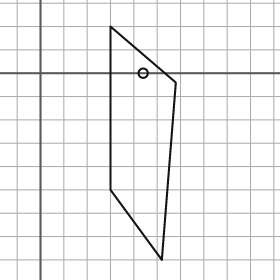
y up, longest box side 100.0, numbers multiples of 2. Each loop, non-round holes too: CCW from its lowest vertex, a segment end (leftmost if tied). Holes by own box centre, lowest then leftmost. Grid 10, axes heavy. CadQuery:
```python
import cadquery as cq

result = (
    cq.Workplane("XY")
    .moveTo(52.0, -80.0)
    .lineTo(58.0, -4.0)
    .lineTo(30.0, 20.0)
    .lineTo(30.0, -50.0)
    .close()
    .moveTo(44.0, 0.0)
    .circle(2.0)
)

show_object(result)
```